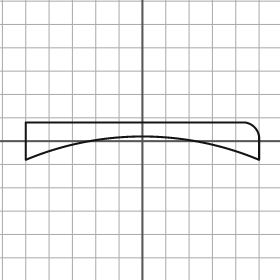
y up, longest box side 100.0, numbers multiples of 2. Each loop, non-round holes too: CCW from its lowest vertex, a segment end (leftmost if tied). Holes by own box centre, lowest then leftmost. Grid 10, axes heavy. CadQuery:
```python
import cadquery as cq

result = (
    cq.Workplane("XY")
    .moveTo(-50.0, -8.0)
    .threePointArc((0.0, 2.0), (50.0, -8.0))
    .lineTo(50.0, 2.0)
    .threePointArc((48.0, 6.0), (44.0, 8.0))
    .lineTo(-50.0, 8.0)
    .close()
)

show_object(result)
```